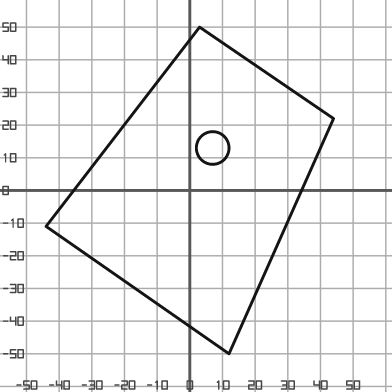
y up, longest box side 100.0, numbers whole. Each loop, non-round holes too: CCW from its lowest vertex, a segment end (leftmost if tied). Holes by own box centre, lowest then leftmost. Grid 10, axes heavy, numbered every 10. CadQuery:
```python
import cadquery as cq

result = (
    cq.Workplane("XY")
    .moveTo(12.0, -50.0)
    .lineTo(44.0, 22.0)
    .lineTo(3.0, 50.0)
    .lineTo(-44.0, -11.0)
    .close()
    .moveTo(7.0, 13.0)
    .circle(5.0)
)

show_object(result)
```